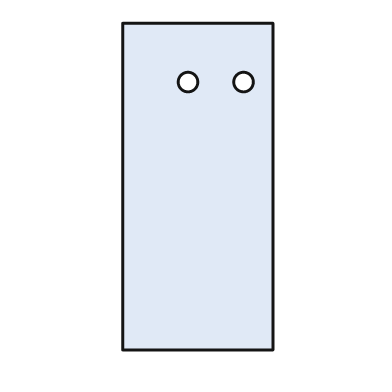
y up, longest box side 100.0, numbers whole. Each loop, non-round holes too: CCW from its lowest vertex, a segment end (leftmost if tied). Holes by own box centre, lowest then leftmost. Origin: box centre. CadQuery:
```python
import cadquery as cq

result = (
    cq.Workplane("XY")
    .moveTo(-23.0, -50.0)
    .lineTo(23.0, -50.0)
    .lineTo(23.0, 50.0)
    .lineTo(-23.0, 50.0)
    .close()
    .moveTo(-3.0, 32.0)
    .circle(3.0)
    .moveTo(14.0, 32.0)
    .circle(3.0)
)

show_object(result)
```